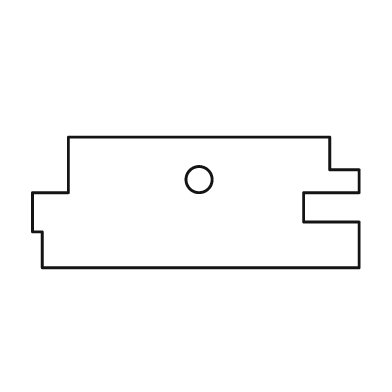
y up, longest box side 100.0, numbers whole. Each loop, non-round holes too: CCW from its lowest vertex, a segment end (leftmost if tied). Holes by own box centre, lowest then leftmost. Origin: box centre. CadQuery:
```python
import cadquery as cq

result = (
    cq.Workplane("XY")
    .moveTo(-47.0, -20.0)
    .lineTo(50.0, -20.0)
    .lineTo(50.0, -6.0)
    .lineTo(33.0, -6.0)
    .lineTo(33.0, 3.0)
    .lineTo(50.0, 3.0)
    .lineTo(50.0, 10.0)
    .lineTo(41.0, 10.0)
    .lineTo(41.0, 20.0)
    .lineTo(-39.0, 20.0)
    .lineTo(-39.0, 3.0)
    .lineTo(-50.0, 3.0)
    .lineTo(-50.0, -9.0)
    .lineTo(-47.0, -9.0)
    .close()
    .moveTo(1.0, 7.0)
    .circle(4.0)
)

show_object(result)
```